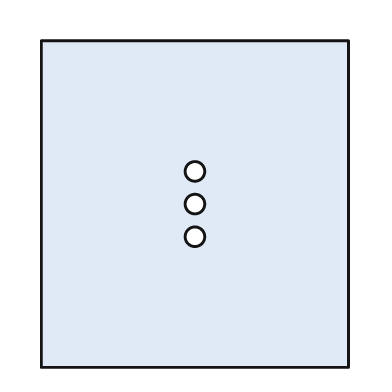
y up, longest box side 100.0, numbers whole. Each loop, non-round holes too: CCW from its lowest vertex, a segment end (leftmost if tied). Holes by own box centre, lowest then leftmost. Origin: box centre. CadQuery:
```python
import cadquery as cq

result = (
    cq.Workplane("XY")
    .moveTo(-47.0, -50.0)
    .lineTo(47.0, -50.0)
    .lineTo(47.0, 50.0)
    .lineTo(-47.0, 50.0)
    .close()
    .moveTo(0.0, -10.0)
    .circle(3.0)
    .moveTo(0.0, 0.0)
    .circle(3.0)
    .moveTo(0.0, 10.0)
    .circle(3.0)
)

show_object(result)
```